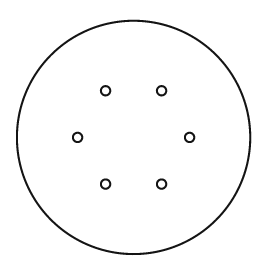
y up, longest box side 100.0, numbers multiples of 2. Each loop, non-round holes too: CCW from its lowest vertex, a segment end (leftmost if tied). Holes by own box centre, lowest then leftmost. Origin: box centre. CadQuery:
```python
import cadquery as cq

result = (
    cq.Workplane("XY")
    .moveTo(0.0, 0.0)
    .circle(50.0)
    .moveTo(-12.0, -20.0)
    .circle(2.0)
    .moveTo(12.0, -20.0)
    .circle(2.0)
    .moveTo(-24.0, 0.0)
    .circle(2.0)
    .moveTo(24.0, 0.0)
    .circle(2.0)
    .moveTo(-12.0, 20.0)
    .circle(2.0)
    .moveTo(12.0, 20.0)
    .circle(2.0)
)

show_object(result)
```